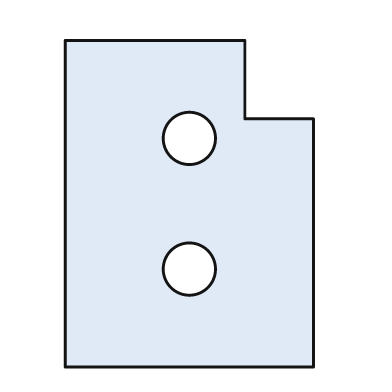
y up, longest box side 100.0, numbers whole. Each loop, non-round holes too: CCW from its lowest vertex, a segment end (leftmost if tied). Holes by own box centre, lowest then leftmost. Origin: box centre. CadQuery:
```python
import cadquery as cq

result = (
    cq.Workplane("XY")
    .moveTo(-38.0, -50.0)
    .lineTo(38.0, -50.0)
    .lineTo(38.0, 26.0)
    .lineTo(17.0, 26.0)
    .lineTo(17.0, 50.0)
    .lineTo(-38.0, 50.0)
    .close()
    .moveTo(0.0, -20.0)
    .circle(8.0)
    .moveTo(0.0, 20.0)
    .circle(8.0)
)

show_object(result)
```